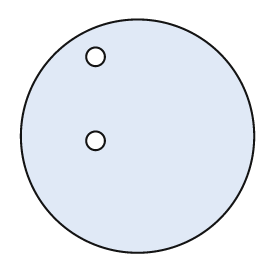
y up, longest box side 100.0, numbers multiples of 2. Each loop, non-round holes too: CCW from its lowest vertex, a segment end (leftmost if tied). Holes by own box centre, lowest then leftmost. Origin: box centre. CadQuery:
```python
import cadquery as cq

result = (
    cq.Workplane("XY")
    .moveTo(0.0, 0.0)
    .circle(50.0)
    .moveTo(-18.0, -2.0)
    .circle(4.0)
    .moveTo(-18.0, 34.0)
    .circle(4.0)
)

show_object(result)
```